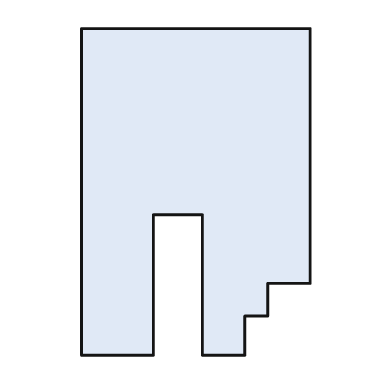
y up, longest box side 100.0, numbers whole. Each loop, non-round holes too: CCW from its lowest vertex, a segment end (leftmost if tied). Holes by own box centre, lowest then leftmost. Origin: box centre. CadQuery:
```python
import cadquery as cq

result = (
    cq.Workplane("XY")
    .moveTo(-35.0, -50.0)
    .lineTo(-13.0, -50.0)
    .lineTo(-13.0, -7.0)
    .lineTo(2.0, -7.0)
    .lineTo(2.0, -50.0)
    .lineTo(15.0, -50.0)
    .lineTo(15.0, -38.0)
    .lineTo(22.0, -38.0)
    .lineTo(22.0, -28.0)
    .lineTo(35.0, -28.0)
    .lineTo(35.0, 50.0)
    .lineTo(-35.0, 50.0)
    .close()
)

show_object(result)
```